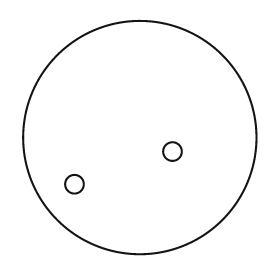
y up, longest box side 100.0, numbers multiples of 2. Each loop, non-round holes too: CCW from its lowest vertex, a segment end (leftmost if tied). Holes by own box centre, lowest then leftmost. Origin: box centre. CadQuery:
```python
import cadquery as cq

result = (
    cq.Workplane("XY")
    .moveTo(0.0, 0.0)
    .circle(50.0)
    .moveTo(-28.0, -20.0)
    .circle(4.0)
    .moveTo(14.0, -6.0)
    .circle(4.0)
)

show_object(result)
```